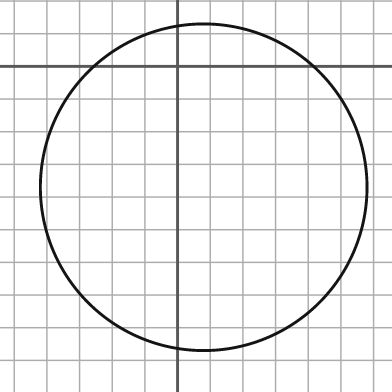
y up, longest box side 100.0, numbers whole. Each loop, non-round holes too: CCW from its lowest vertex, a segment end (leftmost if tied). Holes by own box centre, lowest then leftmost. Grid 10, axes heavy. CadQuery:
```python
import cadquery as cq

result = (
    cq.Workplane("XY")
    .moveTo(8.0, -37.0)
    .circle(50.0)
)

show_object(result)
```